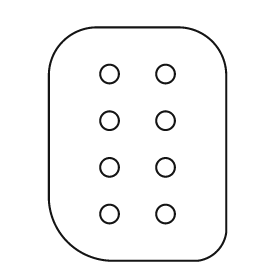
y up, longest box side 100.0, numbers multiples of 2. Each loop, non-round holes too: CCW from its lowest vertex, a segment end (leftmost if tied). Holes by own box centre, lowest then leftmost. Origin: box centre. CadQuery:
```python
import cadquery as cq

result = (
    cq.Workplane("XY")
    .moveTo(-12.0, -50.0)
    .lineTo(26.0, -50.0)
    .threePointArc((34.0, -46.0), (38.0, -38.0))
    .lineTo(38.0, 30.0)
    .threePointArc((32.0, 44.0), (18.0, 50.0))
    .lineTo(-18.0, 50.0)
    .threePointArc((-32.0, 44.0), (-38.0, 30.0))
    .lineTo(-38.0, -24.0)
    .threePointArc((-30.0, -42.0), (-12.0, -50.0))
    .close()
    .moveTo(-12.0, -30.0)
    .circle(4.0)
    .moveTo(12.0, -30.0)
    .circle(4.0)
    .moveTo(-12.0, -10.0)
    .circle(4.0)
    .moveTo(12.0, -10.0)
    .circle(4.0)
    .moveTo(-12.0, 10.0)
    .circle(4.0)
    .moveTo(12.0, 10.0)
    .circle(4.0)
    .moveTo(-12.0, 30.0)
    .circle(4.0)
    .moveTo(12.0, 30.0)
    .circle(4.0)
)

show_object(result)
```